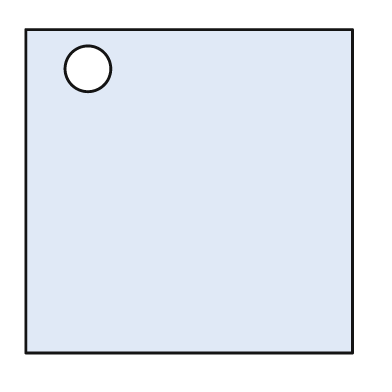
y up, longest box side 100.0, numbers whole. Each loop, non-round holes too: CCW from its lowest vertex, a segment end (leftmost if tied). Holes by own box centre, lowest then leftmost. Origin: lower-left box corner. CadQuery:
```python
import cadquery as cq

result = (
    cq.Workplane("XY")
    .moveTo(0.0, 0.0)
    .lineTo(100.0, 0.0)
    .lineTo(100.0, 99.0)
    .lineTo(0.0, 99.0)
    .close()
    .moveTo(19.0, 87.0)
    .circle(7.0)
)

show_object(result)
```